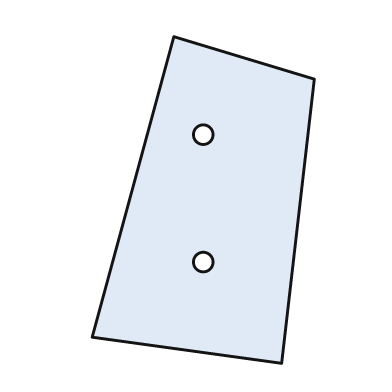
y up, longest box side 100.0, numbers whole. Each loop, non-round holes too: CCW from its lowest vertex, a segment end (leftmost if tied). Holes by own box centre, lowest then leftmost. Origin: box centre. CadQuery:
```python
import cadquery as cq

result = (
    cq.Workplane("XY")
    .moveTo(24.0, -50.0)
    .lineTo(34.0, 37.0)
    .lineTo(-9.0, 50.0)
    .lineTo(-34.0, -42.0)
    .close()
    .moveTo(0.0, -19.0)
    .circle(3.0)
    .moveTo(0.0, 20.0)
    .circle(3.0)
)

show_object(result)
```